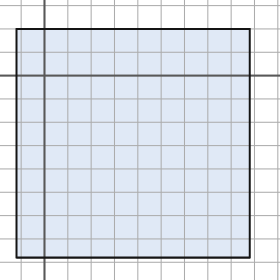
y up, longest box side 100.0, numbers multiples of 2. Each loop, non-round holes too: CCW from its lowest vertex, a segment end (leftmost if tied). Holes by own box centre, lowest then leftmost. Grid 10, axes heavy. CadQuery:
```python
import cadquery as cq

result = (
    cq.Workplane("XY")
    .moveTo(-12.0, -78.0)
    .lineTo(88.0, -78.0)
    .lineTo(88.0, 20.0)
    .lineTo(-12.0, 20.0)
    .close()
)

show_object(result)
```